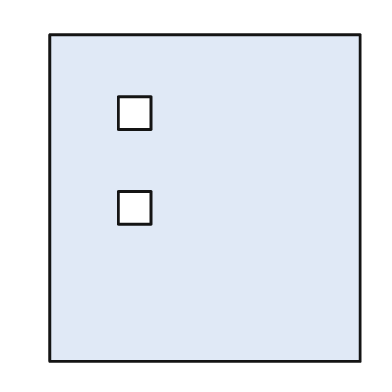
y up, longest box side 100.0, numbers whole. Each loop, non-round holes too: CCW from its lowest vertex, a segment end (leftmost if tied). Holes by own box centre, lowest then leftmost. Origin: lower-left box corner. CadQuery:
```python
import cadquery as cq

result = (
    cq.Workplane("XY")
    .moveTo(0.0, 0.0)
    .lineTo(95.0, 0.0)
    .lineTo(95.0, 100.0)
    .lineTo(0.0, 100.0)
    .close()
    .moveTo(21.0, 42.0)
    .lineTo(31.0, 42.0)
    .lineTo(31.0, 52.0)
    .lineTo(21.0, 52.0)
    .close()
    .moveTo(21.0, 71.0)
    .lineTo(31.0, 71.0)
    .lineTo(31.0, 81.0)
    .lineTo(21.0, 81.0)
    .close()
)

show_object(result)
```